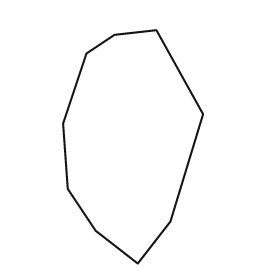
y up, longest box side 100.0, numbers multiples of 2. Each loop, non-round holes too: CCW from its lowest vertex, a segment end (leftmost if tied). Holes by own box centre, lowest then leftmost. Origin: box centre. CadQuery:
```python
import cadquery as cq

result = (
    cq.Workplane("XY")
    .moveTo(2.0, -50.0)
    .lineTo(16.0, -32.0)
    .lineTo(30.0, 14.0)
    .lineTo(10.0, 50.0)
    .lineTo(-8.0, 48.0)
    .lineTo(-20.0, 40.0)
    .lineTo(-30.0, 10.0)
    .lineTo(-28.0, -18.0)
    .lineTo(-16.0, -36.0)
    .close()
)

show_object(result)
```